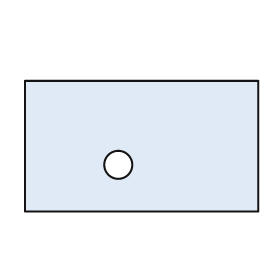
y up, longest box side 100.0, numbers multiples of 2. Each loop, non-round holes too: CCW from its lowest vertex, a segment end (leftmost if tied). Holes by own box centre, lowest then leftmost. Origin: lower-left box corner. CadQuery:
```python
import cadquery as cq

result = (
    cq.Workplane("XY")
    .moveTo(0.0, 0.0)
    .lineTo(100.0, 0.0)
    .lineTo(100.0, 56.0)
    .lineTo(0.0, 56.0)
    .close()
    .moveTo(40.0, 20.0)
    .circle(6.0)
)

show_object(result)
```